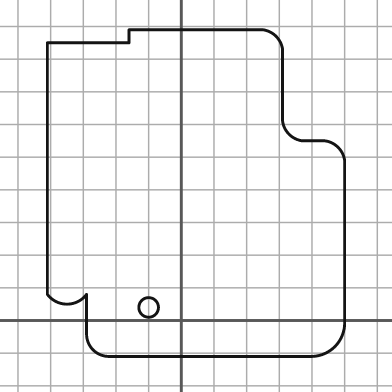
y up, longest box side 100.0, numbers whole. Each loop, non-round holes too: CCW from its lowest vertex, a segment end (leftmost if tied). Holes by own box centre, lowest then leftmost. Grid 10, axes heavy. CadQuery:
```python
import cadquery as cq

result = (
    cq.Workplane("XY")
    .moveTo(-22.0, -11.0)
    .lineTo(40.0, -11.0)
    .threePointArc((47.0, -8.0), (50.0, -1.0))
    .lineTo(50.0, 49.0)
    .threePointArc((48.0, 53.0), (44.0, 55.0))
    .lineTo(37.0, 55.0)
    .threePointArc((33.0, 57.0), (31.0, 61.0))
    .lineTo(31.0, 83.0)
    .threePointArc((29.0, 87.0), (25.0, 89.0))
    .lineTo(-16.0, 89.0)
    .lineTo(-16.0, 85.0)
    .lineTo(-41.0, 85.0)
    .lineTo(-41.0, 8.0)
    .threePointArc((-35.0, 5.0), (-29.0, 8.0))
    .lineTo(-29.0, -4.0)
    .threePointArc((-27.0, -9.0), (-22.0, -11.0))
    .close()
    .moveTo(-10.0, 4.0)
    .circle(3.0)
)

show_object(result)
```